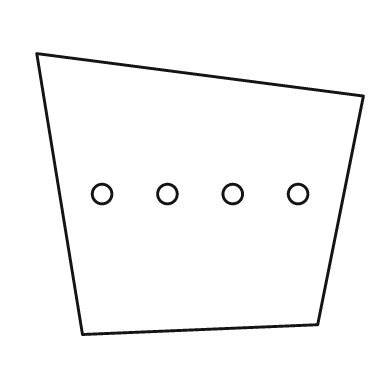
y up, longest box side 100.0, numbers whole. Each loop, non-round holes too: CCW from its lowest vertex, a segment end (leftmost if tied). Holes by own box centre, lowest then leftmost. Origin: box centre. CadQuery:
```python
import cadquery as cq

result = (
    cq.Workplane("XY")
    .moveTo(-36.0, -43.0)
    .lineTo(36.0, -40.0)
    .lineTo(50.0, 30.0)
    .lineTo(-50.0, 43.0)
    .close()
    .moveTo(-30.0, 0.0)
    .circle(3.0)
    .moveTo(-10.0, 0.0)
    .circle(3.0)
    .moveTo(10.0, 0.0)
    .circle(3.0)
    .moveTo(30.0, 0.0)
    .circle(3.0)
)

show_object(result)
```